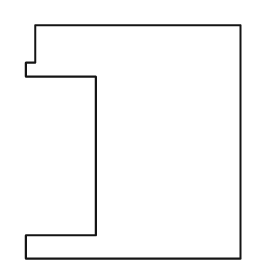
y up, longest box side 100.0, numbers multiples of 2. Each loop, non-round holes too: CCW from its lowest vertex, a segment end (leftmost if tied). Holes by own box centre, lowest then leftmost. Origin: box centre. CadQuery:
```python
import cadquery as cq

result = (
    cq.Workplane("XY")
    .moveTo(-46.0, -50.0)
    .lineTo(46.0, -50.0)
    .lineTo(46.0, 50.0)
    .lineTo(-42.0, 50.0)
    .lineTo(-42.0, 34.0)
    .lineTo(-46.0, 34.0)
    .lineTo(-46.0, 28.0)
    .lineTo(-16.0, 28.0)
    .lineTo(-16.0, -40.0)
    .lineTo(-46.0, -40.0)
    .close()
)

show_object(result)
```